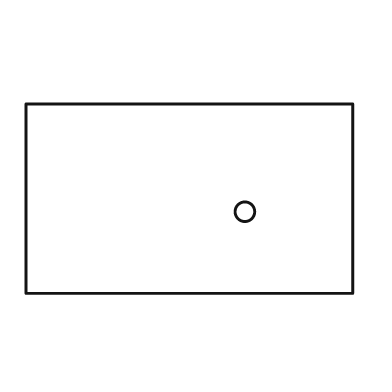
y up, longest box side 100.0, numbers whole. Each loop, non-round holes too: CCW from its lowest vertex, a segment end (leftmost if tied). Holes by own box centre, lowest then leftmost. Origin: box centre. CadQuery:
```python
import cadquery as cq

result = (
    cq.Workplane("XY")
    .moveTo(-50.0, -29.0)
    .lineTo(50.0, -29.0)
    .lineTo(50.0, 29.0)
    .lineTo(-50.0, 29.0)
    .close()
    .moveTo(17.0, -4.0)
    .circle(3.0)
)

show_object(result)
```